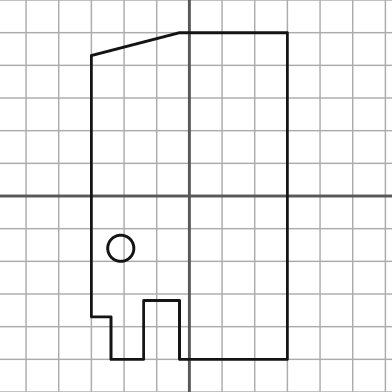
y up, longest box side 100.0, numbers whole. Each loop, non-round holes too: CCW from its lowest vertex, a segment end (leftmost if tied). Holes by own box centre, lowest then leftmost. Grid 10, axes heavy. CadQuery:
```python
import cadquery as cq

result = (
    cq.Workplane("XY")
    .moveTo(-24.0, -50.0)
    .lineTo(-14.0, -50.0)
    .lineTo(-14.0, -32.0)
    .lineTo(-3.0, -32.0)
    .lineTo(-3.0, -50.0)
    .lineTo(30.0, -50.0)
    .lineTo(30.0, 50.0)
    .lineTo(-3.0, 50.0)
    .lineTo(-30.0, 43.0)
    .lineTo(-30.0, -37.0)
    .lineTo(-24.0, -37.0)
    .close()
    .moveTo(-21.0, -16.0)
    .circle(4.0)
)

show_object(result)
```